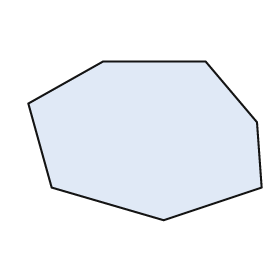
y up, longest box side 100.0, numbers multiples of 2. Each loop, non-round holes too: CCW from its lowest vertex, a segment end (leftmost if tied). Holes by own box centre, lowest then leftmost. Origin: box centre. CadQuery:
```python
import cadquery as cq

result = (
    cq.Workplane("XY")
    .moveTo(8.0, -34.0)
    .lineTo(50.0, -20.0)
    .lineTo(48.0, 8.0)
    .lineTo(26.0, 34.0)
    .lineTo(-18.0, 34.0)
    .lineTo(-50.0, 16.0)
    .lineTo(-40.0, -20.0)
    .close()
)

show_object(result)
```